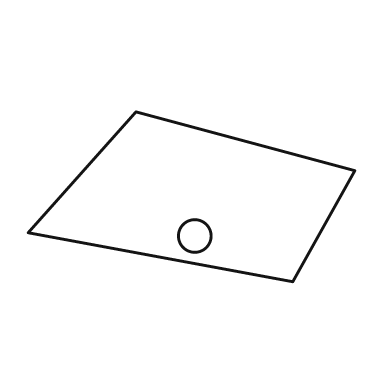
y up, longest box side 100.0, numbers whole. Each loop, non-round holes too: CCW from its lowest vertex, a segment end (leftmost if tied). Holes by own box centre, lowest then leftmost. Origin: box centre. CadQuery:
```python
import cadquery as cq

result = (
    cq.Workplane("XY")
    .moveTo(31.0, -26.0)
    .lineTo(50.0, 8.0)
    .lineTo(-17.0, 26.0)
    .lineTo(-50.0, -11.0)
    .close()
    .moveTo(1.0, -12.0)
    .circle(5.0)
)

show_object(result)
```